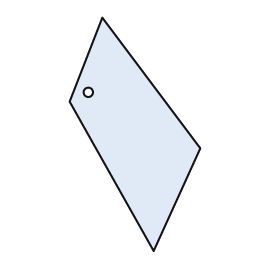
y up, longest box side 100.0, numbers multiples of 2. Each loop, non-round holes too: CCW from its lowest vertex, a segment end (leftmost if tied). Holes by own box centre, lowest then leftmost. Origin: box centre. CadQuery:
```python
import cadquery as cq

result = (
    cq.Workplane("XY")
    .moveTo(8.0, -50.0)
    .lineTo(28.0, -6.0)
    .lineTo(-14.0, 50.0)
    .lineTo(-28.0, 14.0)
    .close()
    .moveTo(-20.0, 18.0)
    .circle(2.0)
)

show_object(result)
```